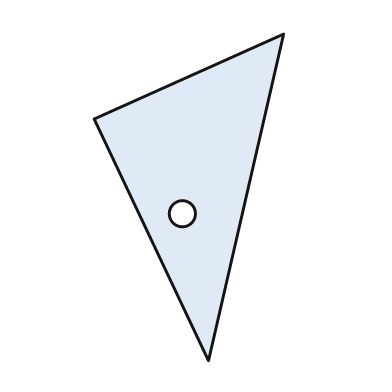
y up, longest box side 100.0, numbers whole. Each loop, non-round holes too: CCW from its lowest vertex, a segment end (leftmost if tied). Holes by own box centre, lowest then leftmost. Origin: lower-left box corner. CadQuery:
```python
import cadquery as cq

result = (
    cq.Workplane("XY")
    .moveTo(35.0, 0.0)
    .lineTo(58.0, 100.0)
    .lineTo(0.0, 74.0)
    .close()
    .moveTo(27.0, 45.0)
    .circle(4.0)
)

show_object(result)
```